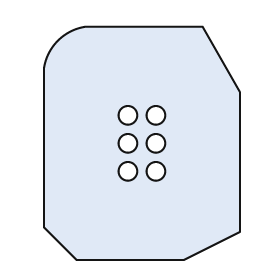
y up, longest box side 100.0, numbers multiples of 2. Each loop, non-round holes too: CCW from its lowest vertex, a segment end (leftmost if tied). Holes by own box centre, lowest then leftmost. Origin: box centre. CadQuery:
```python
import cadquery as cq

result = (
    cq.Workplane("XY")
    .moveTo(-28.0, -50.0)
    .lineTo(18.0, -50.0)
    .lineTo(42.0, -38.0)
    .lineTo(42.0, 22.0)
    .lineTo(26.0, 50.0)
    .lineTo(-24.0, 50.0)
    .threePointArc((-36.0, 44.0), (-42.0, 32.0))
    .lineTo(-42.0, -36.0)
    .close()
    .moveTo(-6.0, -12.0)
    .circle(4.0)
    .moveTo(6.0, -12.0)
    .circle(4.0)
    .moveTo(-6.0, 0.0)
    .circle(4.0)
    .moveTo(6.0, 0.0)
    .circle(4.0)
    .moveTo(-6.0, 12.0)
    .circle(4.0)
    .moveTo(6.0, 12.0)
    .circle(4.0)
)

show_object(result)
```